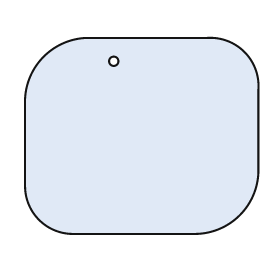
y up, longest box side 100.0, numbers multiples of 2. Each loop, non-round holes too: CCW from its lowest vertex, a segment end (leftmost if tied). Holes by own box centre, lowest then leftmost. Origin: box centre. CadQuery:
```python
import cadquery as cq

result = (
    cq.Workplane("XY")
    .moveTo(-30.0, -42.0)
    .lineTo(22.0, -42.0)
    .threePointArc((42.0, -34.0), (50.0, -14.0))
    .lineTo(50.0, 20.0)
    .threePointArc((44.0, 36.0), (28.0, 42.0))
    .lineTo(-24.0, 42.0)
    .threePointArc((-42.0, 34.0), (-50.0, 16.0))
    .lineTo(-50.0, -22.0)
    .threePointArc((-44.0, -36.0), (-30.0, -42.0))
    .close()
    .moveTo(-12.0, 32.0)
    .circle(2.0)
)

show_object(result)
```